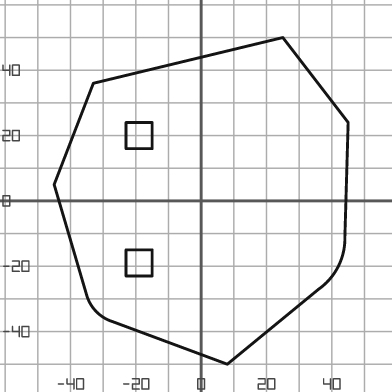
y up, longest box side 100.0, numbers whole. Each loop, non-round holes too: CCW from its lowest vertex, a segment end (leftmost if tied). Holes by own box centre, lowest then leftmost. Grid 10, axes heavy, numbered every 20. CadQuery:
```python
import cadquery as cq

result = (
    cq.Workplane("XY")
    .moveTo(8.0, -50.0)
    .lineTo(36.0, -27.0)
    .threePointArc((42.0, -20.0), (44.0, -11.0))
    .lineTo(45.0, 24.0)
    .lineTo(25.0, 50.0)
    .lineTo(-33.0, 36.0)
    .lineTo(-45.0, 5.0)
    .lineTo(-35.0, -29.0)
    .threePointArc((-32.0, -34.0), (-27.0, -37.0))
    .close()
    .moveTo(-23.0, -23.0)
    .lineTo(-15.0, -23.0)
    .lineTo(-15.0, -15.0)
    .lineTo(-23.0, -15.0)
    .close()
    .moveTo(-23.0, 16.0)
    .lineTo(-15.0, 16.0)
    .lineTo(-15.0, 24.0)
    .lineTo(-23.0, 24.0)
    .close()
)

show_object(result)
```